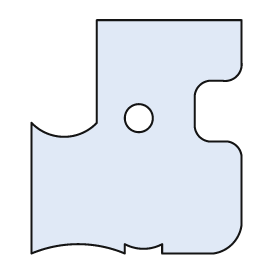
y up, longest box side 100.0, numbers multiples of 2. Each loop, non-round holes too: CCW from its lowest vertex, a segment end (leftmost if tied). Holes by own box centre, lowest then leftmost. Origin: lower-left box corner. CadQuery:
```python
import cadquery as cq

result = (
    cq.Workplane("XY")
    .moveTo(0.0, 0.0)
    .threePointArc((20.0, 4.0), (40.0, 0.0))
    .lineTo(40.0, 4.0)
    .threePointArc((48.0, 2.0), (56.0, 4.0))
    .lineTo(56.0, 0.0)
    .lineTo(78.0, 0.0)
    .threePointArc((86.0, 4.0), (90.0, 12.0))
    .lineTo(90.0, 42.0)
    .threePointArc((88.0, 46.0), (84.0, 48.0))
    .lineTo(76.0, 48.0)
    .threePointArc((72.0, 50.0), (70.0, 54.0))
    .lineTo(70.0, 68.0)
    .threePointArc((72.0, 72.0), (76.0, 74.0))
    .lineTo(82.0, 74.0)
    .threePointArc((88.0, 76.0), (90.0, 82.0))
    .lineTo(90.0, 100.0)
    .lineTo(28.0, 100.0)
    .lineTo(28.0, 56.0)
    .threePointArc((14.0, 50.0), (0.0, 56.0))
    .close()
    .moveTo(46.0, 58.0)
    .circle(6.0)
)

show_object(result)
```